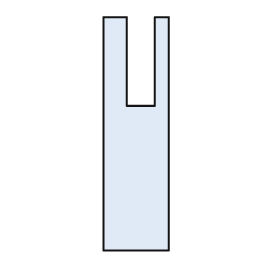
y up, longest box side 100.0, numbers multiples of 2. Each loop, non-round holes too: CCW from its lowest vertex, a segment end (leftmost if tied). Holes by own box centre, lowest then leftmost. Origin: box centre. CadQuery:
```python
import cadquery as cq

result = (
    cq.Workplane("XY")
    .moveTo(-14.0, -50.0)
    .lineTo(14.0, -50.0)
    .lineTo(14.0, 50.0)
    .lineTo(8.0, 50.0)
    .lineTo(8.0, 12.0)
    .lineTo(-4.0, 12.0)
    .lineTo(-4.0, 50.0)
    .lineTo(-14.0, 50.0)
    .close()
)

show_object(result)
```